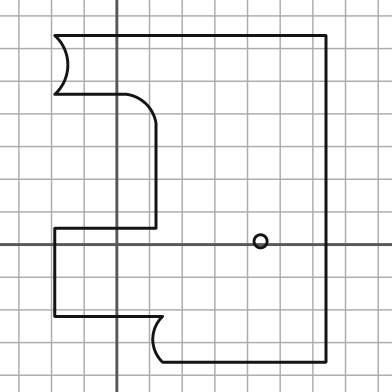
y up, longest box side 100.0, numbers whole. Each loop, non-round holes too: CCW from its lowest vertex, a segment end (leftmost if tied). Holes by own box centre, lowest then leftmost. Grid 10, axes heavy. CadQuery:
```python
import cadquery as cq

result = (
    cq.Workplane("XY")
    .moveTo(14.0, -36.0)
    .lineTo(64.0, -36.0)
    .lineTo(64.0, 64.0)
    .lineTo(-19.0, 64.0)
    .threePointArc((-15.0, 55.0), (-19.0, 46.0))
    .lineTo(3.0, 46.0)
    .threePointArc((9.0, 43.0), (12.0, 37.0))
    .lineTo(12.0, 5.0)
    .lineTo(-19.0, 5.0)
    .lineTo(-19.0, -22.0)
    .lineTo(14.0, -22.0)
    .threePointArc((11.0, -29.0), (14.0, -36.0))
    .close()
    .moveTo(44.0, 1.0)
    .circle(2.0)
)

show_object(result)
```